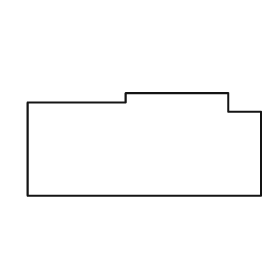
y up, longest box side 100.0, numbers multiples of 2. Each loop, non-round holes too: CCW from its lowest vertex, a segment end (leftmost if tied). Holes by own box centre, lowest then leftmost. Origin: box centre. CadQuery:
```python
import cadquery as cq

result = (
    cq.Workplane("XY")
    .moveTo(-50.0, -22.0)
    .lineTo(50.0, -22.0)
    .lineTo(50.0, 14.0)
    .lineTo(36.0, 14.0)
    .lineTo(36.0, 22.0)
    .lineTo(-8.0, 22.0)
    .lineTo(-8.0, 18.0)
    .lineTo(-50.0, 18.0)
    .close()
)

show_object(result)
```